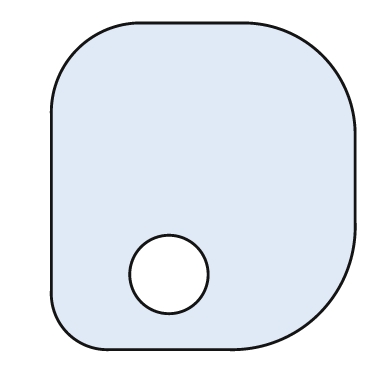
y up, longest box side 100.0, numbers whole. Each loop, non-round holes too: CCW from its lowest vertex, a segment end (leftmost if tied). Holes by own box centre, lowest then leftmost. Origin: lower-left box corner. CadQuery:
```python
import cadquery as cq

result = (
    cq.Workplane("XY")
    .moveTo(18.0, 0.0)
    .lineTo(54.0, 0.0)
    .threePointArc((82.0, 11.0), (93.0, 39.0))
    .lineTo(93.0, 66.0)
    .threePointArc((83.0, 90.0), (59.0, 100.0))
    .lineTo(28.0, 100.0)
    .threePointArc((8.0, 92.0), (0.0, 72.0))
    .lineTo(0.0, 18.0)
    .threePointArc((5.0, 5.0), (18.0, 0.0))
    .close()
    .moveTo(36.0, 23.0)
    .circle(12.0)
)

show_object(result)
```